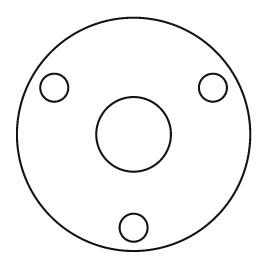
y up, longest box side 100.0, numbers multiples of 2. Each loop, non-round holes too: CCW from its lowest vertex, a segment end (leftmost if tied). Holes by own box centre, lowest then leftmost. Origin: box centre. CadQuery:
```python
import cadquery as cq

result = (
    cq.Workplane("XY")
    .moveTo(0.0, 0.0)
    .circle(50.0)
    .moveTo(0.0, -40.0)
    .circle(6.0)
    .moveTo(0.0, 0.0)
    .circle(16.0)
    .moveTo(-34.0, 20.0)
    .circle(6.0)
    .moveTo(34.0, 20.0)
    .circle(6.0)
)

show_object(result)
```